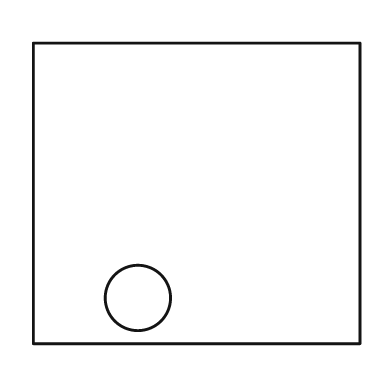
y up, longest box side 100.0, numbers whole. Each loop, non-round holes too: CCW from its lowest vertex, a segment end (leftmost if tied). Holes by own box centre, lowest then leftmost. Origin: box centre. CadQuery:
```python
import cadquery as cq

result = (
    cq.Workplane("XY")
    .moveTo(-50.0, -46.0)
    .lineTo(50.0, -46.0)
    .lineTo(50.0, 46.0)
    .lineTo(-50.0, 46.0)
    .close()
    .moveTo(-18.0, -32.0)
    .circle(10.0)
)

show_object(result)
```